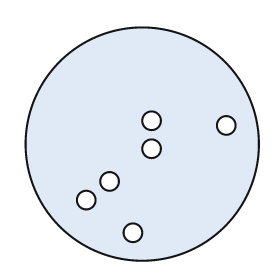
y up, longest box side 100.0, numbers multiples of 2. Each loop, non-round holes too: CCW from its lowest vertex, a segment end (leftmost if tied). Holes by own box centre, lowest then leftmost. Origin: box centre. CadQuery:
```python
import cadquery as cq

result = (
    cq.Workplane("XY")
    .moveTo(0.0, 0.0)
    .circle(50.0)
    .moveTo(-4.0, -38.0)
    .circle(4.0)
    .moveTo(-24.0, -24.0)
    .circle(4.0)
    .moveTo(-14.0, -16.0)
    .circle(4.0)
    .moveTo(4.0, -2.0)
    .circle(4.0)
    .moveTo(36.0, 8.0)
    .circle(4.0)
    .moveTo(4.0, 10.0)
    .circle(4.0)
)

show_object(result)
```